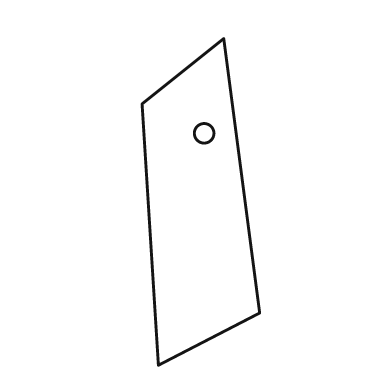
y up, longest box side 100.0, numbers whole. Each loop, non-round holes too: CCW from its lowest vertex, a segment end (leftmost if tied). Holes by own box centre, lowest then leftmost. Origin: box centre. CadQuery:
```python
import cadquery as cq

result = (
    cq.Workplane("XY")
    .moveTo(-13.0, -50.0)
    .lineTo(18.0, -34.0)
    .lineTo(7.0, 50.0)
    .lineTo(-18.0, 30.0)
    .close()
    .moveTo(1.0, 21.0)
    .circle(3.0)
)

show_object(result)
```